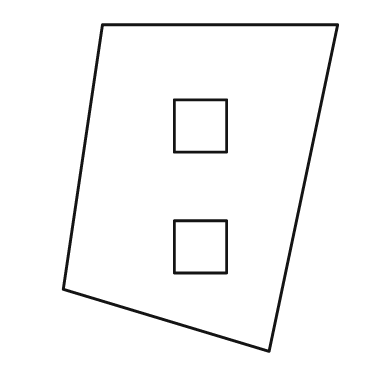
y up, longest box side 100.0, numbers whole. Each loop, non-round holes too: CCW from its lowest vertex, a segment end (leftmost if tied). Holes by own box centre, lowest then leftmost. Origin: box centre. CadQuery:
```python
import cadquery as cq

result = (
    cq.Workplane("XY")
    .moveTo(21.0, -50.0)
    .lineTo(42.0, 50.0)
    .lineTo(-30.0, 50.0)
    .lineTo(-42.0, -31.0)
    .close()
    .moveTo(-8.0, -26.0)
    .lineTo(8.0, -26.0)
    .lineTo(8.0, -10.0)
    .lineTo(-8.0, -10.0)
    .close()
    .moveTo(-8.0, 11.0)
    .lineTo(8.0, 11.0)
    .lineTo(8.0, 27.0)
    .lineTo(-8.0, 27.0)
    .close()
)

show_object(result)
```